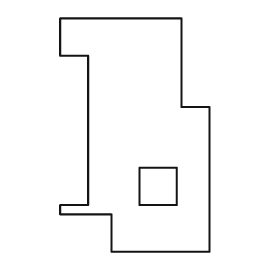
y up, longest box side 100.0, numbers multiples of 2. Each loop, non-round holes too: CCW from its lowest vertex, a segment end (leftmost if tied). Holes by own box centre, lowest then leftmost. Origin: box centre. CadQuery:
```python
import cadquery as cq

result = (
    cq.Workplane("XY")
    .moveTo(-10.0, -50.0)
    .lineTo(32.0, -50.0)
    .lineTo(32.0, 12.0)
    .lineTo(20.0, 12.0)
    .lineTo(20.0, 50.0)
    .lineTo(-32.0, 50.0)
    .lineTo(-32.0, 34.0)
    .lineTo(-20.0, 34.0)
    .lineTo(-20.0, -30.0)
    .lineTo(-32.0, -30.0)
    .lineTo(-32.0, -34.0)
    .lineTo(-10.0, -34.0)
    .close()
    .moveTo(2.0, -30.0)
    .lineTo(18.0, -30.0)
    .lineTo(18.0, -14.0)
    .lineTo(2.0, -14.0)
    .close()
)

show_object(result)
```